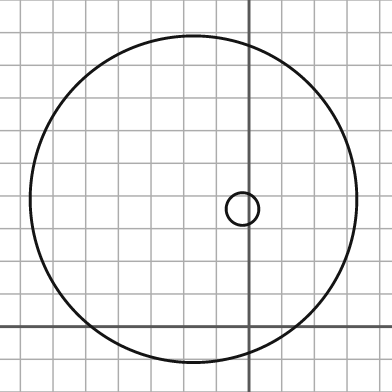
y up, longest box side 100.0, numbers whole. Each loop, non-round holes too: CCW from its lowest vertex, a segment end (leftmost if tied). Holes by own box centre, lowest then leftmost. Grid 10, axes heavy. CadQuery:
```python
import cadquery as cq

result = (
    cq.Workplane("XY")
    .moveTo(-17.0, 39.0)
    .circle(50.0)
    .moveTo(-2.0, 36.0)
    .circle(5.0)
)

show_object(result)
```